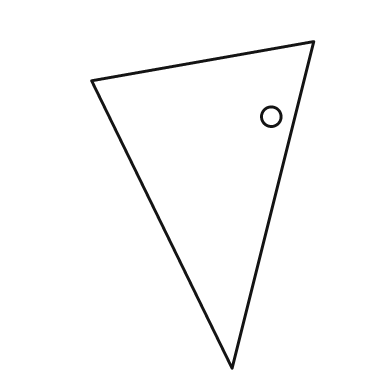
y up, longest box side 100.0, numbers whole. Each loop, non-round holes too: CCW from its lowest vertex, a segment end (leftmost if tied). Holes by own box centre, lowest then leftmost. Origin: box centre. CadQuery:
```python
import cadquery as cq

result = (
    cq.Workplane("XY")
    .moveTo(9.0, -50.0)
    .lineTo(34.0, 50.0)
    .lineTo(-34.0, 38.0)
    .close()
    .moveTo(21.0, 27.0)
    .circle(3.0)
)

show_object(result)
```